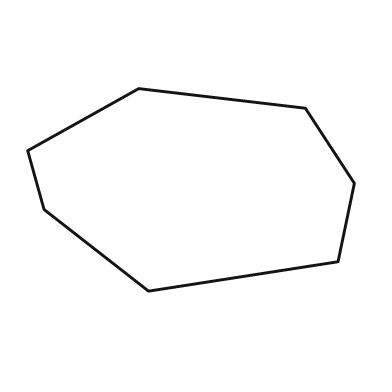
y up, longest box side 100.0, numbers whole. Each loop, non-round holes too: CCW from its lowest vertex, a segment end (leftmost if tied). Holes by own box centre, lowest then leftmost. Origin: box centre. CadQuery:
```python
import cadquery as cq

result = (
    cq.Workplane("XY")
    .moveTo(-13.0, -31.0)
    .lineTo(45.0, -22.0)
    .lineTo(50.0, 2.0)
    .lineTo(35.0, 25.0)
    .lineTo(-16.0, 31.0)
    .lineTo(-50.0, 12.0)
    .lineTo(-45.0, -6.0)
    .close()
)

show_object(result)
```